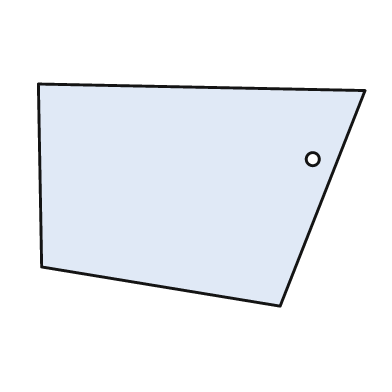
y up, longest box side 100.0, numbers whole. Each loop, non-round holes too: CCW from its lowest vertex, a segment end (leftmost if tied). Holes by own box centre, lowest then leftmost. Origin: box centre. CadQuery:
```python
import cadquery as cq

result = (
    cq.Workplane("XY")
    .moveTo(24.0, -34.0)
    .lineTo(50.0, 32.0)
    .lineTo(-50.0, 34.0)
    .lineTo(-49.0, -22.0)
    .close()
    .moveTo(34.0, 11.0)
    .circle(2.0)
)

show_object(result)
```